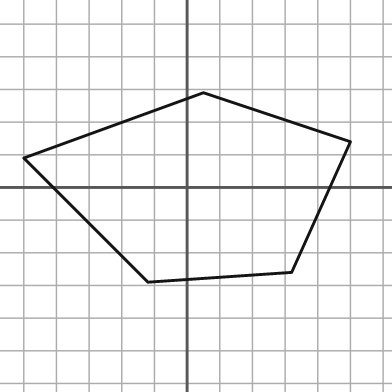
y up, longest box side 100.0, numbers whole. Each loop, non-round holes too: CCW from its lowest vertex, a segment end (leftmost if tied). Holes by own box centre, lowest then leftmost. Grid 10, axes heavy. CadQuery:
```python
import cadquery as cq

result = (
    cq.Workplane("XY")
    .moveTo(-12.0, -29.0)
    .lineTo(32.0, -26.0)
    .lineTo(50.0, 14.0)
    .lineTo(5.0, 29.0)
    .lineTo(-50.0, 9.0)
    .close()
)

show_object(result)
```